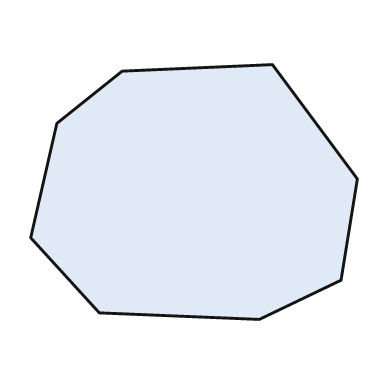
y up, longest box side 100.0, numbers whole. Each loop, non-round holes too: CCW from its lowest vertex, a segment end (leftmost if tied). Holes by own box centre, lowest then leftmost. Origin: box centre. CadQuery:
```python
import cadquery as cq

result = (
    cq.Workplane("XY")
    .moveTo(20.0, -39.0)
    .lineTo(45.0, -27.0)
    .lineTo(50.0, 4.0)
    .lineTo(24.0, 39.0)
    .lineTo(-22.0, 37.0)
    .lineTo(-42.0, 21.0)
    .lineTo(-50.0, -14.0)
    .lineTo(-29.0, -37.0)
    .close()
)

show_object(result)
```